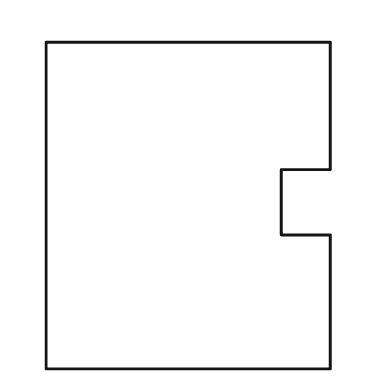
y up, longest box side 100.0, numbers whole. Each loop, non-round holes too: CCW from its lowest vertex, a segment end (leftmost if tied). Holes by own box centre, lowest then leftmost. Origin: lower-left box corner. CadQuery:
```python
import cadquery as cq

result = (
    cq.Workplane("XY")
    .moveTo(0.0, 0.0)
    .lineTo(87.0, 0.0)
    .lineTo(87.0, 41.0)
    .lineTo(72.0, 41.0)
    .lineTo(72.0, 61.0)
    .lineTo(87.0, 61.0)
    .lineTo(87.0, 100.0)
    .lineTo(0.0, 100.0)
    .close()
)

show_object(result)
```